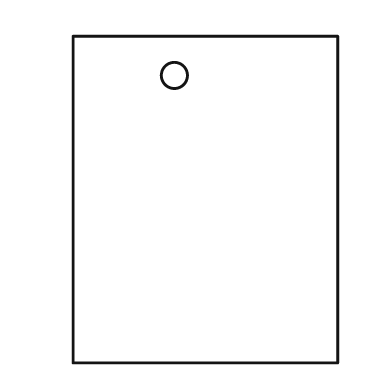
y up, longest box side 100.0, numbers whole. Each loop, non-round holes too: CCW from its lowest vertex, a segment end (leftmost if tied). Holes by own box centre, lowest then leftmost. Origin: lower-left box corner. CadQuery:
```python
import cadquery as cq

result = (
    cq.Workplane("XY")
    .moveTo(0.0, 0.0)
    .lineTo(81.0, 0.0)
    .lineTo(81.0, 100.0)
    .lineTo(0.0, 100.0)
    .close()
    .moveTo(31.0, 88.0)
    .circle(4.0)
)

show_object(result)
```